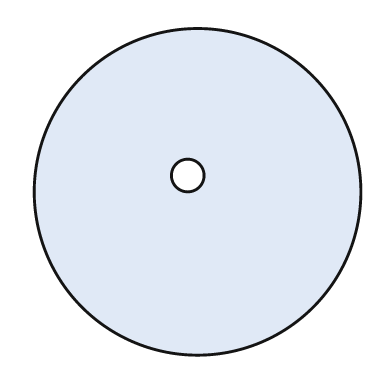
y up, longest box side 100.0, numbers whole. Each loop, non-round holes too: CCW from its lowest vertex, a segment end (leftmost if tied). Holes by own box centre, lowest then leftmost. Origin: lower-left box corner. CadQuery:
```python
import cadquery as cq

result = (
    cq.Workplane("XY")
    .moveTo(50.0, 50.0)
    .circle(50.0)
    .moveTo(47.0, 55.0)
    .circle(5.0)
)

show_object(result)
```